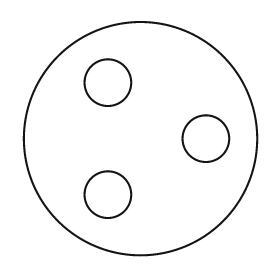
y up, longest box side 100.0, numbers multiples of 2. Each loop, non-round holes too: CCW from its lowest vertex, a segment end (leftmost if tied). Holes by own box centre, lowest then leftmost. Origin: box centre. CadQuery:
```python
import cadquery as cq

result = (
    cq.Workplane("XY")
    .moveTo(0.0, 0.0)
    .circle(50.0)
    .moveTo(-14.0, -24.0)
    .circle(10.0)
    .moveTo(28.0, 0.0)
    .circle(10.0)
    .moveTo(-14.0, 24.0)
    .circle(10.0)
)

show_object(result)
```